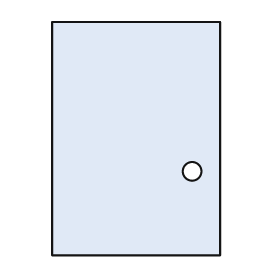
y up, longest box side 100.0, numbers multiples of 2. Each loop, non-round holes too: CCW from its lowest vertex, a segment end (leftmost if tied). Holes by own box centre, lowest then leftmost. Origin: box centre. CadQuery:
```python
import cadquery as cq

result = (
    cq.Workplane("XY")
    .moveTo(-36.0, -50.0)
    .lineTo(36.0, -50.0)
    .lineTo(36.0, 50.0)
    .lineTo(-36.0, 50.0)
    .close()
    .moveTo(24.0, -14.0)
    .circle(4.0)
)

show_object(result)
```